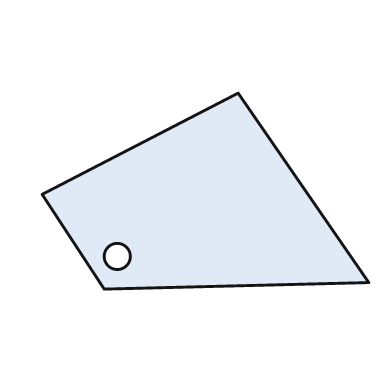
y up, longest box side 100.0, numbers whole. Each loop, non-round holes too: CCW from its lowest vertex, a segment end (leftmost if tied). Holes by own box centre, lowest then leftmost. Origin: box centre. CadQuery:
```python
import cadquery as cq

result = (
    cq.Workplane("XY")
    .moveTo(-31.0, -30.0)
    .lineTo(50.0, -28.0)
    .lineTo(10.0, 30.0)
    .lineTo(-50.0, -1.0)
    .close()
    .moveTo(-27.0, -20.0)
    .circle(4.0)
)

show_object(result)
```